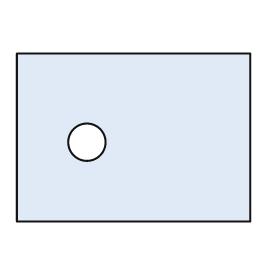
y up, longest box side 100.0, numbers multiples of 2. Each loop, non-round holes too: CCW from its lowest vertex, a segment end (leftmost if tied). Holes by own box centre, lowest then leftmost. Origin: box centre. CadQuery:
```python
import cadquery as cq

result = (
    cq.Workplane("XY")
    .moveTo(-50.0, -36.0)
    .lineTo(50.0, -36.0)
    .lineTo(50.0, 36.0)
    .lineTo(-50.0, 36.0)
    .close()
    .moveTo(-20.0, -2.0)
    .circle(8.0)
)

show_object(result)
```